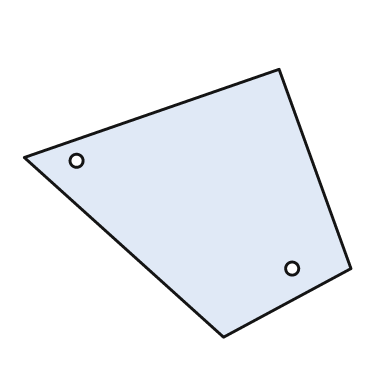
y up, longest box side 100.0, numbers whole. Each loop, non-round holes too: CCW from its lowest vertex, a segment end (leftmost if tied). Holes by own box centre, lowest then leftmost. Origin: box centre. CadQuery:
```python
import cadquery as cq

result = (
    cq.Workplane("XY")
    .moveTo(11.0, -41.0)
    .lineTo(50.0, -20.0)
    .lineTo(28.0, 41.0)
    .lineTo(-50.0, 14.0)
    .close()
    .moveTo(32.0, -20.0)
    .circle(2.0)
    .moveTo(-34.0, 13.0)
    .circle(2.0)
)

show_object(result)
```